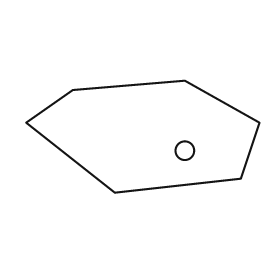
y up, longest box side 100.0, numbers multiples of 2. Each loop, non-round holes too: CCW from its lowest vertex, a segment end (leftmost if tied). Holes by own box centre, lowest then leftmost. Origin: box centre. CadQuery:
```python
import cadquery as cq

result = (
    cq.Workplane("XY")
    .moveTo(-12.0, -24.0)
    .lineTo(42.0, -18.0)
    .lineTo(50.0, 6.0)
    .lineTo(18.0, 24.0)
    .lineTo(-30.0, 20.0)
    .lineTo(-50.0, 6.0)
    .close()
    .moveTo(18.0, -6.0)
    .circle(4.0)
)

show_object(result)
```